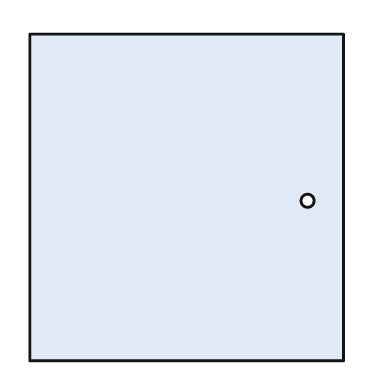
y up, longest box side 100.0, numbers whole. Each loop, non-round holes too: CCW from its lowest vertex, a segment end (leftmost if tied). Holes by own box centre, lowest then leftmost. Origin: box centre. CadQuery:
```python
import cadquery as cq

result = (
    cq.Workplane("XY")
    .moveTo(-48.0, -50.0)
    .lineTo(48.0, -50.0)
    .lineTo(48.0, 50.0)
    .lineTo(-48.0, 50.0)
    .close()
    .moveTo(37.0, -1.0)
    .circle(2.0)
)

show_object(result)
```